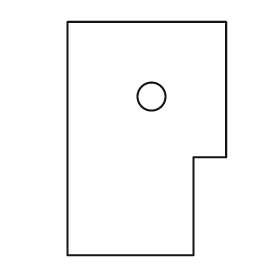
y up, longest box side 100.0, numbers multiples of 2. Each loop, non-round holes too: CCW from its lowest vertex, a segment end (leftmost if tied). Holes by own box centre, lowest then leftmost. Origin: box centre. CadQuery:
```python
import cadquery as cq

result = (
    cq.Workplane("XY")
    .moveTo(-34.0, -50.0)
    .lineTo(20.0, -50.0)
    .lineTo(20.0, -8.0)
    .lineTo(34.0, -8.0)
    .lineTo(34.0, 50.0)
    .lineTo(-34.0, 50.0)
    .close()
    .moveTo(2.0, 18.0)
    .circle(6.0)
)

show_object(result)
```